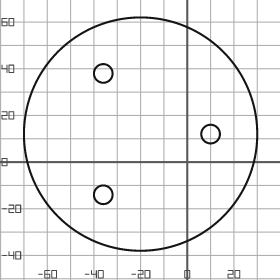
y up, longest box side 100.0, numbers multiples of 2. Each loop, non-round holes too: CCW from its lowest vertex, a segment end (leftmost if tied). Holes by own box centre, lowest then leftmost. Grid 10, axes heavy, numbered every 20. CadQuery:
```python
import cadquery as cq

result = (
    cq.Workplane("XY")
    .moveTo(-20.0, 12.0)
    .circle(50.0)
    .moveTo(-36.0, -14.0)
    .circle(4.0)
    .moveTo(10.0, 12.0)
    .circle(4.0)
    .moveTo(-36.0, 38.0)
    .circle(4.0)
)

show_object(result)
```